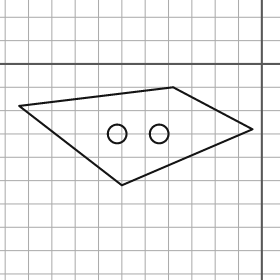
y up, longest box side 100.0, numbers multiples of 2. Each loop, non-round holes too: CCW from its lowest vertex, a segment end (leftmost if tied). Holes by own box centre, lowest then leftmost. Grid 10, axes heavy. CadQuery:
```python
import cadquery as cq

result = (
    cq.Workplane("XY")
    .moveTo(-60.0, -52.0)
    .lineTo(-4.0, -28.0)
    .lineTo(-38.0, -10.0)
    .lineTo(-104.0, -18.0)
    .close()
    .moveTo(-62.0, -30.0)
    .circle(4.0)
    .moveTo(-44.0, -30.0)
    .circle(4.0)
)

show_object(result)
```